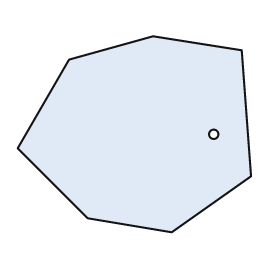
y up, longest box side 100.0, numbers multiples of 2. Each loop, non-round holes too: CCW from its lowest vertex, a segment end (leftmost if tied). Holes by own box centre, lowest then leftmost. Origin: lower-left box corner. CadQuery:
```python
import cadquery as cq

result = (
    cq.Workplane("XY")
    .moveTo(66.0, 0.0)
    .lineTo(100.0, 24.0)
    .lineTo(96.0, 78.0)
    .lineTo(58.0, 84.0)
    .lineTo(22.0, 74.0)
    .lineTo(0.0, 36.0)
    .lineTo(30.0, 6.0)
    .close()
    .moveTo(84.0, 42.0)
    .circle(2.0)
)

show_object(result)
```